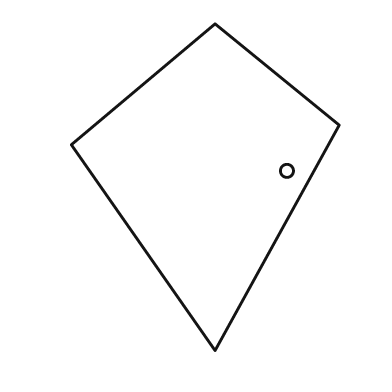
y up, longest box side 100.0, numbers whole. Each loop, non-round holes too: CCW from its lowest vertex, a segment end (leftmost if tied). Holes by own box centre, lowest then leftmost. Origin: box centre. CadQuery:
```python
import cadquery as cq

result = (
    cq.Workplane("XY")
    .moveTo(3.0, -50.0)
    .lineTo(41.0, 19.0)
    .lineTo(3.0, 50.0)
    .lineTo(-41.0, 13.0)
    .close()
    .moveTo(25.0, 5.0)
    .circle(2.0)
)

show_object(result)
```